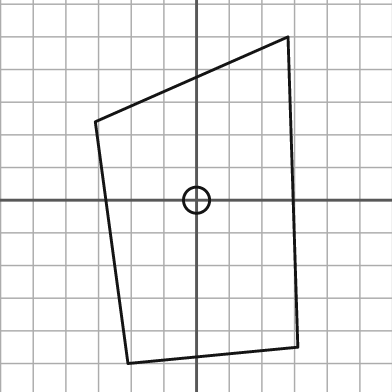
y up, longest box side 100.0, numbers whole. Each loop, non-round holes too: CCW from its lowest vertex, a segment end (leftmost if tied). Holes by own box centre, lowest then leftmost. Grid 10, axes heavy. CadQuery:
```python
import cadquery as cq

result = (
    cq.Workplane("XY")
    .moveTo(-21.0, -50.0)
    .lineTo(31.0, -45.0)
    .lineTo(28.0, 50.0)
    .lineTo(-31.0, 24.0)
    .close()
    .moveTo(0.0, 0.0)
    .circle(4.0)
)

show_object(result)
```